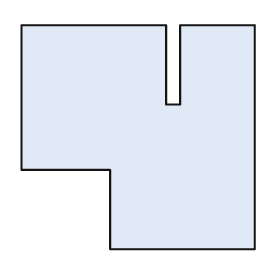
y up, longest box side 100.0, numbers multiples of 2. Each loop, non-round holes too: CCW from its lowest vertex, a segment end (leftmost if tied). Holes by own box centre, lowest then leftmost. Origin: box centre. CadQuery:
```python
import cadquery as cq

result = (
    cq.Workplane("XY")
    .moveTo(-12.0, -48.0)
    .lineTo(50.0, -48.0)
    .lineTo(50.0, 48.0)
    .lineTo(18.0, 48.0)
    .lineTo(18.0, 14.0)
    .lineTo(12.0, 14.0)
    .lineTo(12.0, 48.0)
    .lineTo(-50.0, 48.0)
    .lineTo(-50.0, -14.0)
    .lineTo(-12.0, -14.0)
    .close()
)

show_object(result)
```